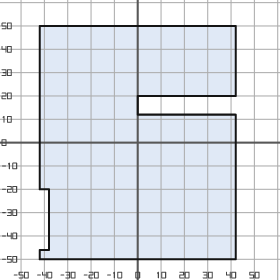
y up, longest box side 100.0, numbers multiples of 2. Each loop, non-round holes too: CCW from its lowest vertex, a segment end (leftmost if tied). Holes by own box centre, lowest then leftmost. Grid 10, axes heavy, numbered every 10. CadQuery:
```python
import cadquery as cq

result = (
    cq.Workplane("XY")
    .moveTo(-42.0, -50.0)
    .lineTo(42.0, -50.0)
    .lineTo(42.0, 12.0)
    .lineTo(0.0, 12.0)
    .lineTo(0.0, 20.0)
    .lineTo(42.0, 20.0)
    .lineTo(42.0, 50.0)
    .lineTo(-42.0, 50.0)
    .lineTo(-42.0, -20.0)
    .lineTo(-38.0, -20.0)
    .lineTo(-38.0, -46.0)
    .lineTo(-42.0, -46.0)
    .close()
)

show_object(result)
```